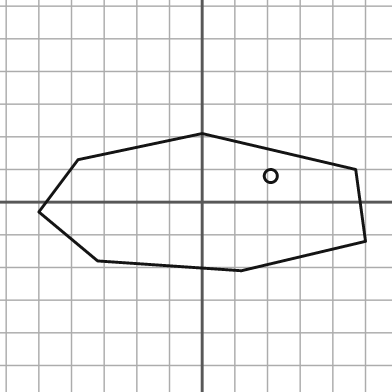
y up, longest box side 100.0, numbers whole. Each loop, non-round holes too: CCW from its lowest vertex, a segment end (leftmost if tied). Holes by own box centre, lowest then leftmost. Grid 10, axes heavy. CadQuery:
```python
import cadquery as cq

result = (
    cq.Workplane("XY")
    .moveTo(12.0, -21.0)
    .lineTo(50.0, -12.0)
    .lineTo(47.0, 10.0)
    .lineTo(0.0, 21.0)
    .lineTo(-38.0, 13.0)
    .lineTo(-50.0, -3.0)
    .lineTo(-32.0, -18.0)
    .close()
    .moveTo(21.0, 8.0)
    .circle(2.0)
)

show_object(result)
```